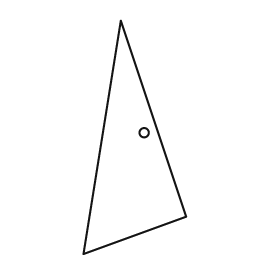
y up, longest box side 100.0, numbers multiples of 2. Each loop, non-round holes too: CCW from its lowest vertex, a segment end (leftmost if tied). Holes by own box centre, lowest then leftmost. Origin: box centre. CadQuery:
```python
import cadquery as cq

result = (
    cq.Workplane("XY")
    .moveTo(-22.0, -50.0)
    .lineTo(22.0, -34.0)
    .lineTo(-6.0, 50.0)
    .close()
    .moveTo(4.0, 2.0)
    .circle(2.0)
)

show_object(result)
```